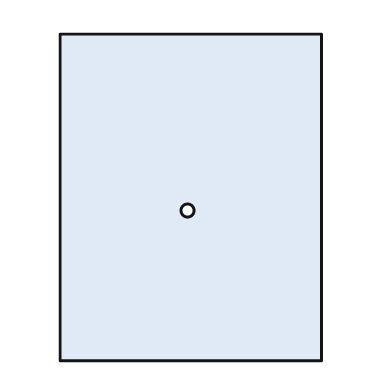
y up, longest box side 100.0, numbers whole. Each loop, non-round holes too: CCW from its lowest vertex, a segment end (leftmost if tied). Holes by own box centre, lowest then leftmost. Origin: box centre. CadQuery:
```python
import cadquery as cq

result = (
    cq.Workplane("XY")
    .moveTo(-40.0, -50.0)
    .lineTo(40.0, -50.0)
    .lineTo(40.0, 50.0)
    .lineTo(-40.0, 50.0)
    .close()
    .moveTo(-1.0, -4.0)
    .circle(2.0)
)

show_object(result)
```